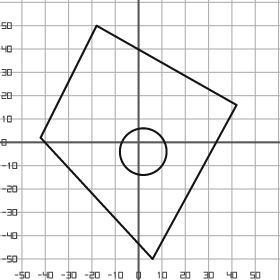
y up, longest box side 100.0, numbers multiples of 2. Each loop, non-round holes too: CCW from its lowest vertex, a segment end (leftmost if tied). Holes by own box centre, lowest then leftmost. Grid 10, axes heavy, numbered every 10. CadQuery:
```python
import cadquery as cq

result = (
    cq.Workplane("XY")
    .moveTo(6.0, -50.0)
    .lineTo(42.0, 16.0)
    .lineTo(-18.0, 50.0)
    .lineTo(-42.0, 2.0)
    .close()
    .moveTo(2.0, -4.0)
    .circle(10.0)
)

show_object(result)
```